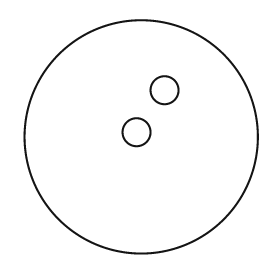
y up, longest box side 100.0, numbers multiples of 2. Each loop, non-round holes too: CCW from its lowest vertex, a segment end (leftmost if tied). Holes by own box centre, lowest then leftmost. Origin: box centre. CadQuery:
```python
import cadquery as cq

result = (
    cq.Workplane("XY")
    .moveTo(0.0, 0.0)
    .circle(50.0)
    .moveTo(-2.0, 2.0)
    .circle(6.0)
    .moveTo(10.0, 20.0)
    .circle(6.0)
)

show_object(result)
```